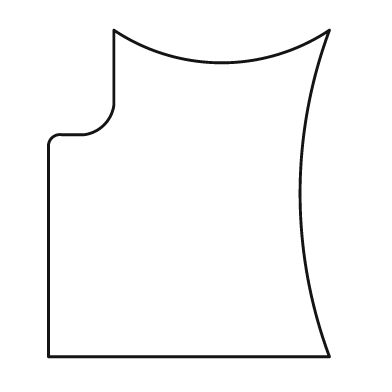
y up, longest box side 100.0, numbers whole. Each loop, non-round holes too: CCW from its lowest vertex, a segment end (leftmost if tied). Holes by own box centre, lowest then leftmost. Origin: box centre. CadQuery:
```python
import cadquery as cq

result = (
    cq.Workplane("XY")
    .moveTo(-43.0, -50.0)
    .lineTo(43.0, -50.0)
    .threePointArc((34.0, 0.0), (43.0, 50.0))
    .threePointArc((10.0, 40.0), (-23.0, 50.0))
    .lineTo(-23.0, 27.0)
    .threePointArc((-26.0, 21.0), (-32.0, 18.0))
    .lineTo(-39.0, 18.0)
    .threePointArc((-42.0, 17.0), (-43.0, 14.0))
    .close()
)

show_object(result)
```